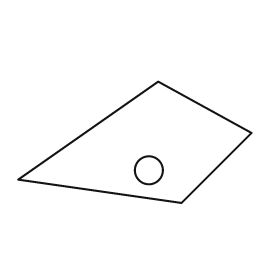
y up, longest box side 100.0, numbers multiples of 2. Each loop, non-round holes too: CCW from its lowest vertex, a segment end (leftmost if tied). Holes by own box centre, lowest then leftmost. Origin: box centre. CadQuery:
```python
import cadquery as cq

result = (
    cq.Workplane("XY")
    .moveTo(20.0, -26.0)
    .lineTo(50.0, 4.0)
    .lineTo(10.0, 26.0)
    .lineTo(-50.0, -16.0)
    .close()
    .moveTo(6.0, -12.0)
    .circle(6.0)
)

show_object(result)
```